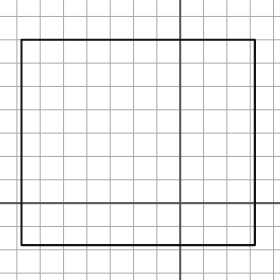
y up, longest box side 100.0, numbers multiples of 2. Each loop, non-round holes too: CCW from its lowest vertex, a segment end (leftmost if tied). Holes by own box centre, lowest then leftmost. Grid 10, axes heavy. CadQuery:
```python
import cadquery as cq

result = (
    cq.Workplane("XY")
    .moveTo(-68.0, -18.0)
    .lineTo(32.0, -18.0)
    .lineTo(32.0, 70.0)
    .lineTo(-68.0, 70.0)
    .close()
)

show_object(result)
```